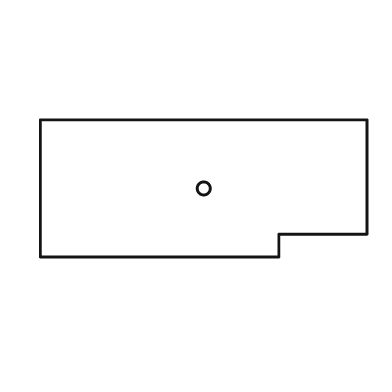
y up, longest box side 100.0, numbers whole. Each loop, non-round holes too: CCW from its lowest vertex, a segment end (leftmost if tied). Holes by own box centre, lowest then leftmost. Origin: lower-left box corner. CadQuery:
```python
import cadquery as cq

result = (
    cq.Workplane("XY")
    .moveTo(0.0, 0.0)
    .lineTo(73.0, 0.0)
    .lineTo(73.0, 7.0)
    .lineTo(100.0, 7.0)
    .lineTo(100.0, 42.0)
    .lineTo(0.0, 42.0)
    .close()
    .moveTo(50.0, 21.0)
    .circle(2.0)
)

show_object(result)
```